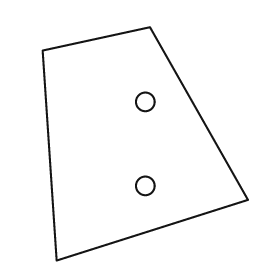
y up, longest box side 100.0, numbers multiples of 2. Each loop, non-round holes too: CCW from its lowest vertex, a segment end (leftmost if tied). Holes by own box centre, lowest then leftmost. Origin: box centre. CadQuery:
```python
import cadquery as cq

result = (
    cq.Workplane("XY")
    .moveTo(-38.0, -50.0)
    .lineTo(44.0, -24.0)
    .lineTo(2.0, 50.0)
    .lineTo(-44.0, 40.0)
    .close()
    .moveTo(0.0, -18.0)
    .circle(4.0)
    .moveTo(0.0, 18.0)
    .circle(4.0)
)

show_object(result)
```